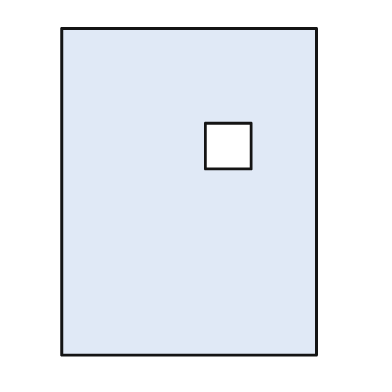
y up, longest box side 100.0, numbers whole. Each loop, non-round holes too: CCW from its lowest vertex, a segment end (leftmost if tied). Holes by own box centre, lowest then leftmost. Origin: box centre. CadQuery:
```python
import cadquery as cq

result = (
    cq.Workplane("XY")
    .moveTo(-39.0, -50.0)
    .lineTo(39.0, -50.0)
    .lineTo(39.0, 50.0)
    .lineTo(-39.0, 50.0)
    .close()
    .moveTo(5.0, 7.0)
    .lineTo(19.0, 7.0)
    .lineTo(19.0, 21.0)
    .lineTo(5.0, 21.0)
    .close()
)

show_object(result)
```